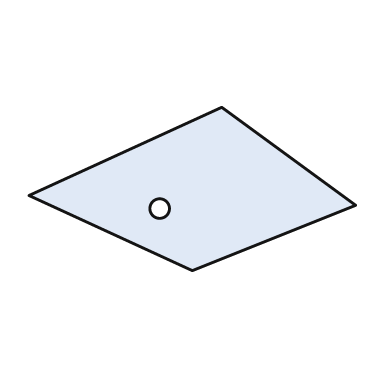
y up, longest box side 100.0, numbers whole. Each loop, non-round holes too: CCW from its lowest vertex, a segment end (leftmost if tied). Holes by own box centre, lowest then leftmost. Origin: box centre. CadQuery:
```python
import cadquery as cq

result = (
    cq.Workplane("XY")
    .moveTo(0.0, -25.0)
    .lineTo(50.0, -5.0)
    .lineTo(9.0, 25.0)
    .lineTo(-50.0, -2.0)
    .close()
    .moveTo(-10.0, -6.0)
    .circle(3.0)
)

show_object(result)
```